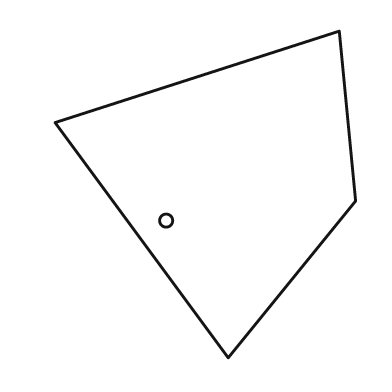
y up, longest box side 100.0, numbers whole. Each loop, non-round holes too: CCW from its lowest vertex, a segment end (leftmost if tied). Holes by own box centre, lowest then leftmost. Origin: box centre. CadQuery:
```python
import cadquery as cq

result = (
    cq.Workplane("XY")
    .moveTo(7.0, -50.0)
    .lineTo(46.0, -2.0)
    .lineTo(41.0, 50.0)
    .lineTo(-46.0, 22.0)
    .close()
    .moveTo(-12.0, -8.0)
    .circle(2.0)
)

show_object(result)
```